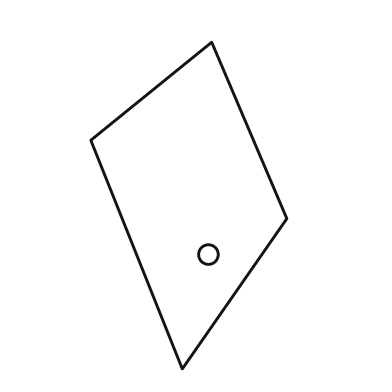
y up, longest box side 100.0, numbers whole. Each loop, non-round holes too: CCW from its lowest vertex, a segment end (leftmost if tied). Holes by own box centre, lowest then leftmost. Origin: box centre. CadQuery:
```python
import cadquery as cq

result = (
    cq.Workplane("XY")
    .moveTo(-2.0, -50.0)
    .lineTo(30.0, -4.0)
    .lineTo(7.0, 50.0)
    .lineTo(-30.0, 20.0)
    .close()
    .moveTo(6.0, -15.0)
    .circle(3.0)
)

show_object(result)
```